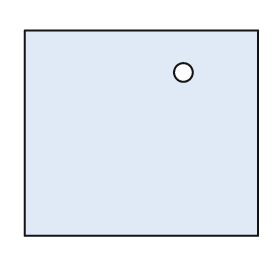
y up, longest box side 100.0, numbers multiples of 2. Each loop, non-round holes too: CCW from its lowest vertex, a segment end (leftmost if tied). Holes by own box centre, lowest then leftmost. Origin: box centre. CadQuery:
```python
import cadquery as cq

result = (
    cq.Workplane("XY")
    .moveTo(-50.0, -44.0)
    .lineTo(50.0, -44.0)
    .lineTo(50.0, 44.0)
    .lineTo(-50.0, 44.0)
    .close()
    .moveTo(18.0, 26.0)
    .circle(4.0)
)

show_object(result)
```